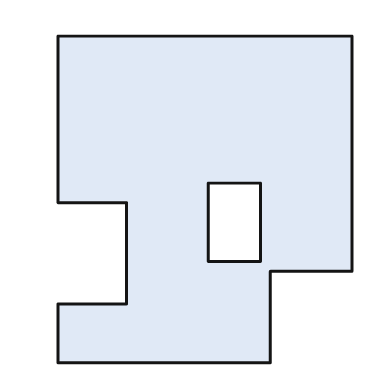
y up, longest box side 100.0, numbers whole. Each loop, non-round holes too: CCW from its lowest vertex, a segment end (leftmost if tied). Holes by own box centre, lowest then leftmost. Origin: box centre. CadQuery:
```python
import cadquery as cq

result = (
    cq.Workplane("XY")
    .moveTo(-45.0, -50.0)
    .lineTo(20.0, -50.0)
    .lineTo(20.0, -22.0)
    .lineTo(45.0, -22.0)
    .lineTo(45.0, 50.0)
    .lineTo(-45.0, 50.0)
    .lineTo(-45.0, -1.0)
    .lineTo(-24.0, -1.0)
    .lineTo(-24.0, -32.0)
    .lineTo(-45.0, -32.0)
    .close()
    .moveTo(1.0, -19.0)
    .lineTo(17.0, -19.0)
    .lineTo(17.0, 5.0)
    .lineTo(1.0, 5.0)
    .close()
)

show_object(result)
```